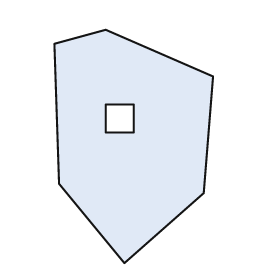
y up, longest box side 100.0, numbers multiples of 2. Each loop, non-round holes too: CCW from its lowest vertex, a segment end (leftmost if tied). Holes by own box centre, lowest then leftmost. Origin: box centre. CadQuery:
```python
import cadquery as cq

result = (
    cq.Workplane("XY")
    .moveTo(-4.0, -50.0)
    .lineTo(30.0, -20.0)
    .lineTo(34.0, 30.0)
    .lineTo(-12.0, 50.0)
    .lineTo(-34.0, 44.0)
    .lineTo(-32.0, -16.0)
    .close()
    .moveTo(-12.0, 6.0)
    .lineTo(0.0, 6.0)
    .lineTo(0.0, 18.0)
    .lineTo(-12.0, 18.0)
    .close()
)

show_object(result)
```